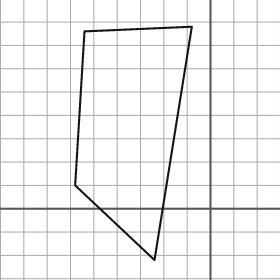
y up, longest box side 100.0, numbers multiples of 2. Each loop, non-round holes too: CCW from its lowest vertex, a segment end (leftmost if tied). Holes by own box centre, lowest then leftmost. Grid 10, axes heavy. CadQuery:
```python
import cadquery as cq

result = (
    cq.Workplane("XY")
    .moveTo(-24.0, -22.0)
    .lineTo(-8.0, 78.0)
    .lineTo(-54.0, 76.0)
    .lineTo(-58.0, 10.0)
    .close()
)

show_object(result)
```